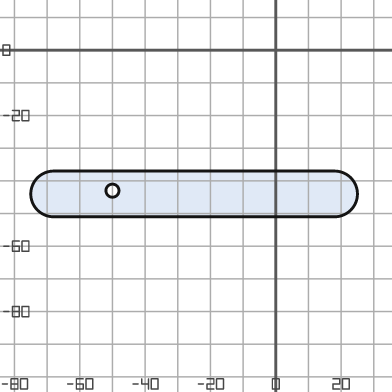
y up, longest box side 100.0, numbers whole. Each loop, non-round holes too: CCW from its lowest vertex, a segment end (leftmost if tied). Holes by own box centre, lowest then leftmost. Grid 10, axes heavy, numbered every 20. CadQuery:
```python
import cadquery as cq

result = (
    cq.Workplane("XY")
    .moveTo(-68.0, -51.0)
    .lineTo(18.0, -51.0)
    .threePointArc((25.0, -44.0), (18.0, -37.0))
    .lineTo(-68.0, -37.0)
    .threePointArc((-75.0, -44.0), (-68.0, -51.0))
    .close()
    .moveTo(-50.0, -43.0)
    .circle(2.0)
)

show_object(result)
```